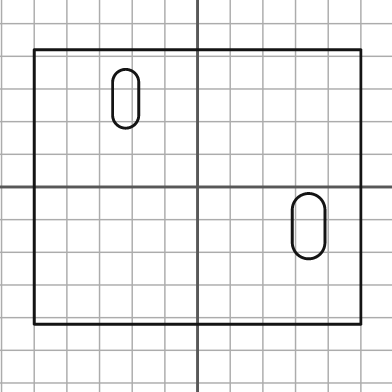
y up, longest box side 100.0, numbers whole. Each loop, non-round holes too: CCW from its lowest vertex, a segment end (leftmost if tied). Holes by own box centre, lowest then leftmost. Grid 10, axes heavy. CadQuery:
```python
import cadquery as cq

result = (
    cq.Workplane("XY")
    .moveTo(-50.0, -42.0)
    .lineTo(50.0, -42.0)
    .lineTo(50.0, 42.0)
    .lineTo(-50.0, 42.0)
    .close()
    .moveTo(29.0, -17.0)
    .threePointArc((34.0, -22.0), (39.0, -17.0))
    .lineTo(39.0, -7.0)
    .threePointArc((34.0, -2.0), (29.0, -7.0))
    .close()
    .moveTo(-26.0, 22.0)
    .threePointArc((-22.0, 18.0), (-18.0, 22.0))
    .lineTo(-18.0, 32.0)
    .threePointArc((-22.0, 36.0), (-26.0, 32.0))
    .close()
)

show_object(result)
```